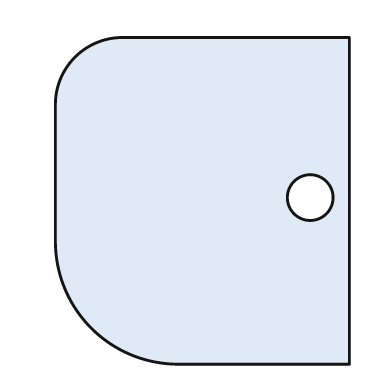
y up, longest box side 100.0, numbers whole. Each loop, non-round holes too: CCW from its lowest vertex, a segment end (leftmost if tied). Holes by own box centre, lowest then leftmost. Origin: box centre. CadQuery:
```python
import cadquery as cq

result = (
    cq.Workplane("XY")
    .moveTo(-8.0, -50.0)
    .lineTo(45.0, -50.0)
    .lineTo(45.0, 50.0)
    .lineTo(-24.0, 50.0)
    .threePointArc((-39.0, 44.0), (-45.0, 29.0))
    .lineTo(-45.0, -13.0)
    .threePointArc((-34.0, -39.0), (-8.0, -50.0))
    .close()
    .moveTo(33.0, 1.0)
    .circle(7.0)
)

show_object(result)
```